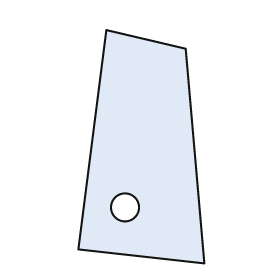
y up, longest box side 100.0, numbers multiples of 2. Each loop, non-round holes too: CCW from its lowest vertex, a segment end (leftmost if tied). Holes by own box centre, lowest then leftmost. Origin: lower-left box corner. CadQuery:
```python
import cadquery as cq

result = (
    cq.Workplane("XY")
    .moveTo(54.0, 0.0)
    .lineTo(46.0, 92.0)
    .lineTo(12.0, 100.0)
    .lineTo(0.0, 6.0)
    .close()
    .moveTo(20.0, 24.0)
    .circle(6.0)
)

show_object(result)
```